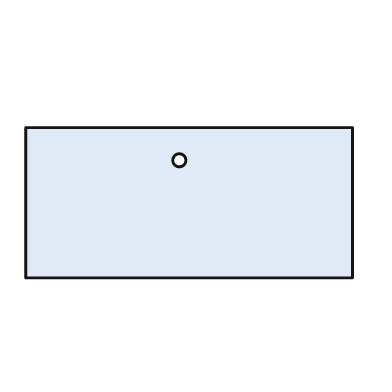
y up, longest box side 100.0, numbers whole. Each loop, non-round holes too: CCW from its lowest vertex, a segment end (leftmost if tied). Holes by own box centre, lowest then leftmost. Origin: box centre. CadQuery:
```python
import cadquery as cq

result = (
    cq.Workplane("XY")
    .moveTo(-50.0, -23.0)
    .lineTo(50.0, -23.0)
    .lineTo(50.0, 23.0)
    .lineTo(-50.0, 23.0)
    .close()
    .moveTo(-3.0, 13.0)
    .circle(2.0)
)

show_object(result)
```